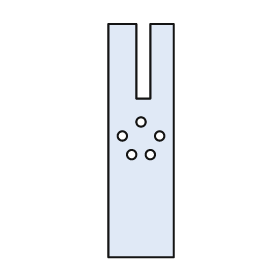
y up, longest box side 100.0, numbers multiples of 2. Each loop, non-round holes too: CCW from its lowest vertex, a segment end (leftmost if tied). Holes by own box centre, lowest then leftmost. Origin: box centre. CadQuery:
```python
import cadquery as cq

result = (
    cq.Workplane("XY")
    .moveTo(-14.0, -50.0)
    .lineTo(14.0, -50.0)
    .lineTo(14.0, 50.0)
    .lineTo(4.0, 50.0)
    .lineTo(4.0, 18.0)
    .lineTo(-2.0, 18.0)
    .lineTo(-2.0, 50.0)
    .lineTo(-14.0, 50.0)
    .close()
    .moveTo(-4.0, -6.0)
    .circle(2.0)
    .moveTo(4.0, -6.0)
    .circle(2.0)
    .moveTo(-8.0, 2.0)
    .circle(2.0)
    .moveTo(8.0, 2.0)
    .circle(2.0)
    .moveTo(0.0, 8.0)
    .circle(2.0)
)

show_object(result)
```